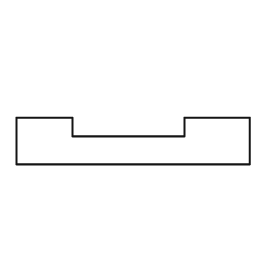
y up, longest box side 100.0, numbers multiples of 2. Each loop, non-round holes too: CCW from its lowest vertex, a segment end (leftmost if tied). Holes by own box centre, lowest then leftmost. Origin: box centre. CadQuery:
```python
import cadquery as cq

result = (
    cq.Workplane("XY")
    .moveTo(-50.0, -10.0)
    .lineTo(50.0, -10.0)
    .lineTo(50.0, 10.0)
    .lineTo(22.0, 10.0)
    .lineTo(22.0, 2.0)
    .lineTo(-26.0, 2.0)
    .lineTo(-26.0, 10.0)
    .lineTo(-50.0, 10.0)
    .close()
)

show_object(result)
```